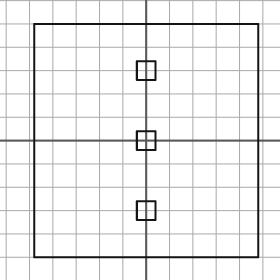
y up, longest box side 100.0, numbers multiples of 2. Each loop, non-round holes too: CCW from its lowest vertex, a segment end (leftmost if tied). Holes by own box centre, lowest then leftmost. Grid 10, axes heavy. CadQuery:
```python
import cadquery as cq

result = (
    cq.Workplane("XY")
    .moveTo(-48.0, -50.0)
    .lineTo(48.0, -50.0)
    .lineTo(48.0, 50.0)
    .lineTo(-48.0, 50.0)
    .close()
    .moveTo(-4.0, -34.0)
    .lineTo(4.0, -34.0)
    .lineTo(4.0, -26.0)
    .lineTo(-4.0, -26.0)
    .close()
    .moveTo(-4.0, -4.0)
    .lineTo(4.0, -4.0)
    .lineTo(4.0, 4.0)
    .lineTo(-4.0, 4.0)
    .close()
    .moveTo(-4.0, 26.0)
    .lineTo(4.0, 26.0)
    .lineTo(4.0, 34.0)
    .lineTo(-4.0, 34.0)
    .close()
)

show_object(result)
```